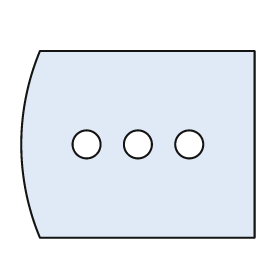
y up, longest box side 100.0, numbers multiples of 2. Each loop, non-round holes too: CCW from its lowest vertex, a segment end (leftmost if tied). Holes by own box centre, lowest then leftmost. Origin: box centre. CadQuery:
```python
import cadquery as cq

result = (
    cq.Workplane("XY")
    .moveTo(-42.0, -40.0)
    .lineTo(50.0, -40.0)
    .lineTo(50.0, 40.0)
    .lineTo(-42.0, 40.0)
    .threePointArc((-50.0, 0.0), (-42.0, -40.0))
    .close()
    .moveTo(-22.0, 0.0)
    .circle(6.0)
    .moveTo(0.0, 0.0)
    .circle(6.0)
    .moveTo(22.0, 0.0)
    .circle(6.0)
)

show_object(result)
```